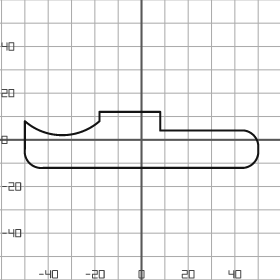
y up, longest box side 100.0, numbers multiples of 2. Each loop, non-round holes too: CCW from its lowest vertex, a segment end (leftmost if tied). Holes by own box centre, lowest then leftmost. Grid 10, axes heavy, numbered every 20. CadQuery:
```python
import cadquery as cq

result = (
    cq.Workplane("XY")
    .moveTo(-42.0, -12.0)
    .lineTo(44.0, -12.0)
    .threePointArc((48.0, -10.0), (50.0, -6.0))
    .lineTo(50.0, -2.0)
    .threePointArc((48.0, 2.0), (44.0, 4.0))
    .lineTo(8.0, 4.0)
    .lineTo(8.0, 12.0)
    .lineTo(-18.0, 12.0)
    .lineTo(-18.0, 8.0)
    .threePointArc((-34.0, 2.0), (-50.0, 8.0))
    .lineTo(-50.0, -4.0)
    .threePointArc((-48.0, -10.0), (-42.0, -12.0))
    .close()
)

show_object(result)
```